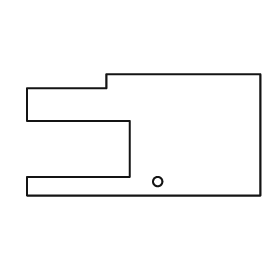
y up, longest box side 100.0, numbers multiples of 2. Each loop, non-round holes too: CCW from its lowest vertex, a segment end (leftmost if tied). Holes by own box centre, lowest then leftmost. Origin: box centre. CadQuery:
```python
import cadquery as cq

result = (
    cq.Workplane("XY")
    .moveTo(-50.0, -26.0)
    .lineTo(50.0, -26.0)
    .lineTo(50.0, 26.0)
    .lineTo(-16.0, 26.0)
    .lineTo(-16.0, 20.0)
    .lineTo(-50.0, 20.0)
    .lineTo(-50.0, 6.0)
    .lineTo(-6.0, 6.0)
    .lineTo(-6.0, -18.0)
    .lineTo(-50.0, -18.0)
    .close()
    .moveTo(6.0, -20.0)
    .circle(2.0)
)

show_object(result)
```